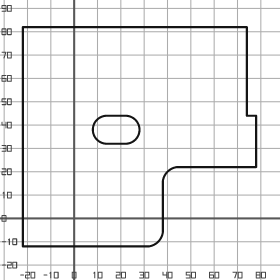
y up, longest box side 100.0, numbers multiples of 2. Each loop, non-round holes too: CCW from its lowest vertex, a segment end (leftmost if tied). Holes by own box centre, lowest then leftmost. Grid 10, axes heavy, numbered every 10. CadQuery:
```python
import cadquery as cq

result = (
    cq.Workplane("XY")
    .moveTo(-22.0, -12.0)
    .lineTo(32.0, -12.0)
    .threePointArc((36.0, -10.0), (38.0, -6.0))
    .lineTo(38.0, 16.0)
    .threePointArc((40.0, 20.0), (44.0, 22.0))
    .lineTo(78.0, 22.0)
    .lineTo(78.0, 44.0)
    .lineTo(74.0, 44.0)
    .lineTo(74.0, 82.0)
    .lineTo(-22.0, 82.0)
    .close()
    .moveTo(14.0, 32.0)
    .lineTo(22.0, 32.0)
    .threePointArc((28.0, 38.0), (22.0, 44.0))
    .lineTo(14.0, 44.0)
    .threePointArc((8.0, 38.0), (14.0, 32.0))
    .close()
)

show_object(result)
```